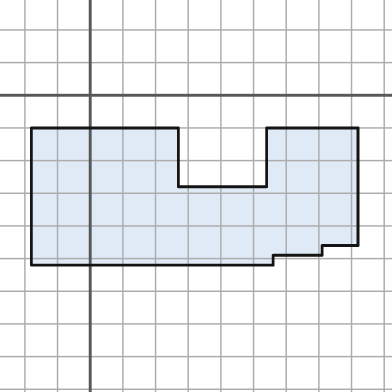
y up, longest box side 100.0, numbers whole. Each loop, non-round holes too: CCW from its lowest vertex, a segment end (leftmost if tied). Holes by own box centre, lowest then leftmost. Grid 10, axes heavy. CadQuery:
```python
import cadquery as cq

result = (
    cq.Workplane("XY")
    .moveTo(-18.0, -52.0)
    .lineTo(56.0, -52.0)
    .lineTo(56.0, -49.0)
    .lineTo(71.0, -49.0)
    .lineTo(71.0, -46.0)
    .lineTo(82.0, -46.0)
    .lineTo(82.0, -10.0)
    .lineTo(54.0, -10.0)
    .lineTo(54.0, -28.0)
    .lineTo(27.0, -28.0)
    .lineTo(27.0, -10.0)
    .lineTo(-18.0, -10.0)
    .close()
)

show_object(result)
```